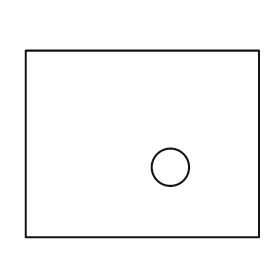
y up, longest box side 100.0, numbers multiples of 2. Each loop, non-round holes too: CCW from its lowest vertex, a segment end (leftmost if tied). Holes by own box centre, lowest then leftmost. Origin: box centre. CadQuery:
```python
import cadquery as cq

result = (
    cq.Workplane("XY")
    .moveTo(-50.0, -40.0)
    .lineTo(50.0, -40.0)
    .lineTo(50.0, 40.0)
    .lineTo(-50.0, 40.0)
    .close()
    .moveTo(12.0, -10.0)
    .circle(8.0)
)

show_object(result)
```